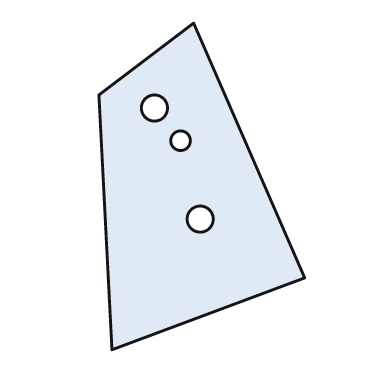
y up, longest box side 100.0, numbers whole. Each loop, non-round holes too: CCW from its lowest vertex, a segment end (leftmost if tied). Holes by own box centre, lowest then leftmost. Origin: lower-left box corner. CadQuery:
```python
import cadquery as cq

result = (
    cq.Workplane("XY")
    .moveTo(4.0, 0.0)
    .lineTo(63.0, 22.0)
    .lineTo(29.0, 100.0)
    .lineTo(0.0, 78.0)
    .close()
    .moveTo(31.0, 40.0)
    .circle(4.0)
    .moveTo(25.0, 64.0)
    .circle(3.0)
    .moveTo(17.0, 74.0)
    .circle(4.0)
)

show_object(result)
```